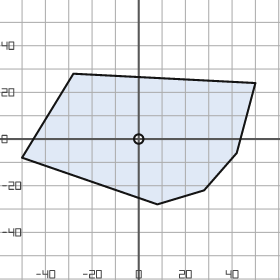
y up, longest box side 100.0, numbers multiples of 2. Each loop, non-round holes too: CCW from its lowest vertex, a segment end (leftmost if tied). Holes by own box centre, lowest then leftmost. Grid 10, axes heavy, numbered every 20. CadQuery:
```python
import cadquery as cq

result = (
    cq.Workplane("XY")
    .moveTo(8.0, -28.0)
    .lineTo(28.0, -22.0)
    .lineTo(42.0, -6.0)
    .lineTo(50.0, 24.0)
    .lineTo(-28.0, 28.0)
    .lineTo(-50.0, -8.0)
    .close()
    .moveTo(0.0, 0.0)
    .circle(2.0)
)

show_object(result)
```